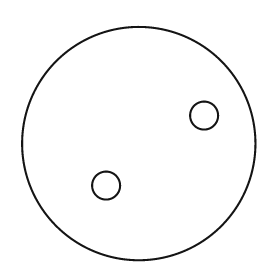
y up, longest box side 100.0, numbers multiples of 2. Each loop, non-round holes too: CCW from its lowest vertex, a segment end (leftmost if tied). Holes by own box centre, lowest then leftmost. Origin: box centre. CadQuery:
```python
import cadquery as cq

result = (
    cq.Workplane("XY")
    .moveTo(0.0, 0.0)
    .circle(50.0)
    .moveTo(-14.0, -18.0)
    .circle(6.0)
    .moveTo(28.0, 12.0)
    .circle(6.0)
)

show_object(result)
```